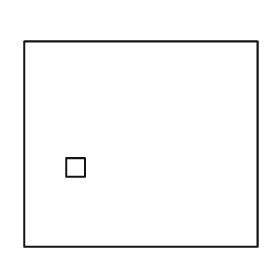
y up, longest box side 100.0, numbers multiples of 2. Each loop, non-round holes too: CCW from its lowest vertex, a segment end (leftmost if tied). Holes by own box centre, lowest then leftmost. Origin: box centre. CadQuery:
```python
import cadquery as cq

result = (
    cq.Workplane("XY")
    .moveTo(-50.0, -44.0)
    .lineTo(50.0, -44.0)
    .lineTo(50.0, 44.0)
    .lineTo(-50.0, 44.0)
    .close()
    .moveTo(-32.0, -14.0)
    .lineTo(-24.0, -14.0)
    .lineTo(-24.0, -6.0)
    .lineTo(-32.0, -6.0)
    .close()
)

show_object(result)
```